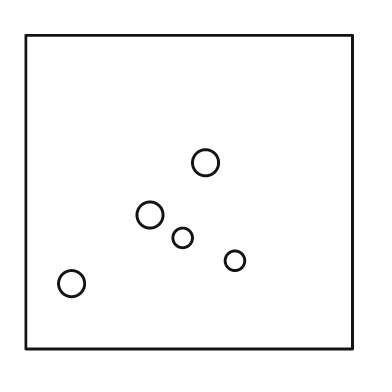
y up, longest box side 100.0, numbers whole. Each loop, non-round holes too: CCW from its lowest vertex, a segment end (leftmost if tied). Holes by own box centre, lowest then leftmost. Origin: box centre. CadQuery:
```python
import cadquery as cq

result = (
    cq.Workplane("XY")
    .moveTo(-50.0, -48.0)
    .lineTo(50.0, -48.0)
    .lineTo(50.0, 48.0)
    .lineTo(-50.0, 48.0)
    .close()
    .moveTo(-36.0, -28.0)
    .circle(4.0)
    .moveTo(14.0, -21.0)
    .circle(3.0)
    .moveTo(-2.0, -14.0)
    .circle(3.0)
    .moveTo(-12.0, -7.0)
    .circle(4.0)
    .moveTo(5.0, 9.0)
    .circle(4.0)
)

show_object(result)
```